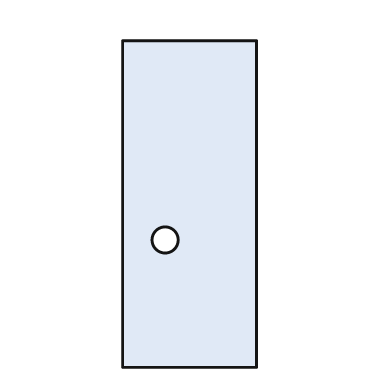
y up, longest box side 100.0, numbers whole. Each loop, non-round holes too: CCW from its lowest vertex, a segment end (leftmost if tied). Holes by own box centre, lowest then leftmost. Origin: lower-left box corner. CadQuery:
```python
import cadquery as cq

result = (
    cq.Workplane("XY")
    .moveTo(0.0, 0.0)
    .lineTo(41.0, 0.0)
    .lineTo(41.0, 100.0)
    .lineTo(0.0, 100.0)
    .close()
    .moveTo(13.0, 39.0)
    .circle(4.0)
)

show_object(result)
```